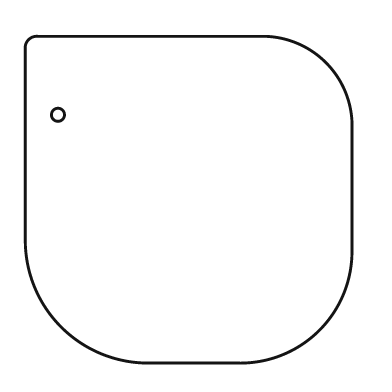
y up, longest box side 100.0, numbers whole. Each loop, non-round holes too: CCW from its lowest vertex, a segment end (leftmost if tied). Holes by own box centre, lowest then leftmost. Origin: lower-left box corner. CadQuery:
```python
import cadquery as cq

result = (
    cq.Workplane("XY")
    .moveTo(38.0, 0.0)
    .lineTo(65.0, 0.0)
    .threePointArc((90.0, 10.0), (100.0, 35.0))
    .lineTo(100.0, 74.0)
    .threePointArc((92.0, 92.0), (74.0, 100.0))
    .lineTo(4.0, 100.0)
    .threePointArc((1.0, 99.0), (0.0, 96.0))
    .lineTo(0.0, 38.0)
    .threePointArc((11.0, 11.0), (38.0, 0.0))
    .close()
    .moveTo(10.0, 76.0)
    .circle(2.0)
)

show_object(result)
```